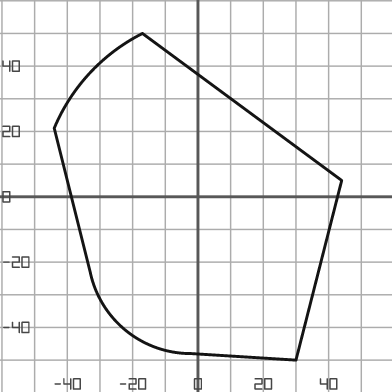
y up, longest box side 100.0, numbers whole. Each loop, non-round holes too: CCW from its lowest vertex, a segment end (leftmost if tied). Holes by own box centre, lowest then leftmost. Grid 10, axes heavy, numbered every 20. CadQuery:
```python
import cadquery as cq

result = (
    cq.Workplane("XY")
    .moveTo(30.0, -50.0)
    .lineTo(44.0, 5.0)
    .lineTo(-17.0, 50.0)
    .threePointArc((-33.0, 38.0), (-44.0, 21.0))
    .lineTo(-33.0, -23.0)
    .threePointArc((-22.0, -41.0), (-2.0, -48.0))
    .close()
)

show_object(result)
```